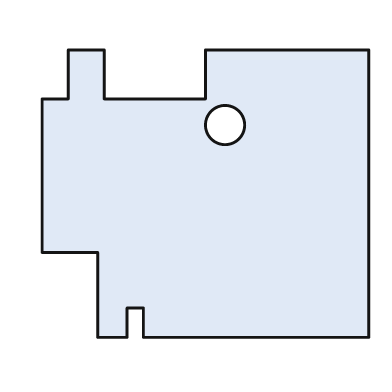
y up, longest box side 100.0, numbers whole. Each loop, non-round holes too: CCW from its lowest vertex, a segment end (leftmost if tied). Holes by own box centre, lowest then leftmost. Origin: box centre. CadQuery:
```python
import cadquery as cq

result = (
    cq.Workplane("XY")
    .moveTo(-33.0, -44.0)
    .lineTo(-24.0, -44.0)
    .lineTo(-24.0, -35.0)
    .lineTo(-19.0, -35.0)
    .lineTo(-19.0, -44.0)
    .lineTo(50.0, -44.0)
    .lineTo(50.0, 44.0)
    .lineTo(0.0, 44.0)
    .lineTo(0.0, 29.0)
    .lineTo(-31.0, 29.0)
    .lineTo(-31.0, 44.0)
    .lineTo(-42.0, 44.0)
    .lineTo(-42.0, 29.0)
    .lineTo(-50.0, 29.0)
    .lineTo(-50.0, -18.0)
    .lineTo(-33.0, -18.0)
    .close()
    .moveTo(6.0, 21.0)
    .circle(6.0)
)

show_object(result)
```